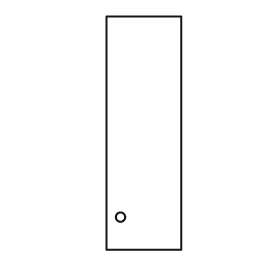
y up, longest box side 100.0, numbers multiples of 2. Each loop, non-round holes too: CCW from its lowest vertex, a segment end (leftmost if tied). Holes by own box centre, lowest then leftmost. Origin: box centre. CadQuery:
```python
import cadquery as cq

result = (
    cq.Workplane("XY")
    .moveTo(-16.0, -50.0)
    .lineTo(16.0, -50.0)
    .lineTo(16.0, 50.0)
    .lineTo(-16.0, 50.0)
    .close()
    .moveTo(-10.0, -36.0)
    .circle(2.0)
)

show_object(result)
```